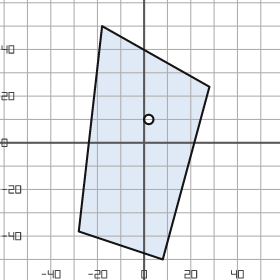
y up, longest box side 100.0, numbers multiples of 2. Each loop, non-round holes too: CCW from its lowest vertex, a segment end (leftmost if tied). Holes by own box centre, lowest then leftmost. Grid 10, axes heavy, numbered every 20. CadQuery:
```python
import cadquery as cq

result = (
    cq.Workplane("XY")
    .moveTo(8.0, -50.0)
    .lineTo(28.0, 24.0)
    .lineTo(-18.0, 50.0)
    .lineTo(-28.0, -38.0)
    .close()
    .moveTo(2.0, 10.0)
    .circle(2.0)
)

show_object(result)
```